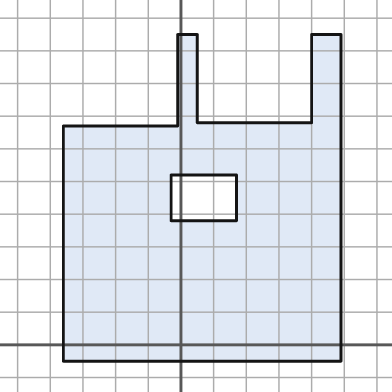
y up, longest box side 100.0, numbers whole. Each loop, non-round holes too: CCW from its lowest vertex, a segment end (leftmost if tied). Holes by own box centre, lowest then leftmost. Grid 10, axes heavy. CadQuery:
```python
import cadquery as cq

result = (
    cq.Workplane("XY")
    .moveTo(-36.0, -5.0)
    .lineTo(49.0, -5.0)
    .lineTo(49.0, 95.0)
    .lineTo(40.0, 95.0)
    .lineTo(40.0, 68.0)
    .lineTo(5.0, 68.0)
    .lineTo(5.0, 95.0)
    .lineTo(-1.0, 95.0)
    .lineTo(-1.0, 67.0)
    .lineTo(-36.0, 67.0)
    .close()
    .moveTo(-3.0, 38.0)
    .lineTo(17.0, 38.0)
    .lineTo(17.0, 52.0)
    .lineTo(-3.0, 52.0)
    .close()
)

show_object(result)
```